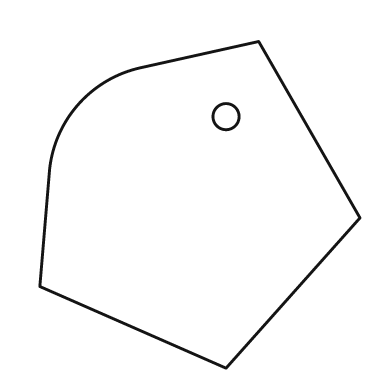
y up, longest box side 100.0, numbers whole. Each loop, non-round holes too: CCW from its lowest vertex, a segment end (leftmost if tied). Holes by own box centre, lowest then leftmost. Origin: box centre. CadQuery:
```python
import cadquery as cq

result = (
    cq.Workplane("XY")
    .moveTo(8.0, -50.0)
    .lineTo(49.0, -4.0)
    .lineTo(18.0, 50.0)
    .lineTo(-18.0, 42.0)
    .threePointArc((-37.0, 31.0), (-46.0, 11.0))
    .lineTo(-49.0, -25.0)
    .close()
    .moveTo(8.0, 27.0)
    .circle(4.0)
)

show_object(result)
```